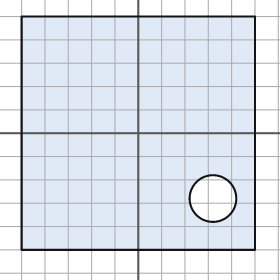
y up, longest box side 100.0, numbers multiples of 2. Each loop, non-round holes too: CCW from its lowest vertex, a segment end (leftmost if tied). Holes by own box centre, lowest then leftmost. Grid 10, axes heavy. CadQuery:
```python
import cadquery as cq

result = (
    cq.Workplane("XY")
    .moveTo(-50.0, -50.0)
    .lineTo(50.0, -50.0)
    .lineTo(50.0, 50.0)
    .lineTo(-50.0, 50.0)
    .close()
    .moveTo(32.0, -28.0)
    .circle(10.0)
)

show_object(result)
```